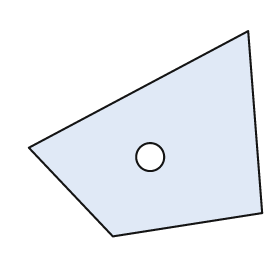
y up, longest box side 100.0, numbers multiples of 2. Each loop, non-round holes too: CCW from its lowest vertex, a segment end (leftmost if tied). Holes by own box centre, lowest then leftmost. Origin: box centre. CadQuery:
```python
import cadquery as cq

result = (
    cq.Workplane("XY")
    .moveTo(-14.0, -44.0)
    .lineTo(50.0, -34.0)
    .lineTo(44.0, 44.0)
    .lineTo(-50.0, -6.0)
    .close()
    .moveTo(2.0, -10.0)
    .circle(6.0)
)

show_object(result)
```